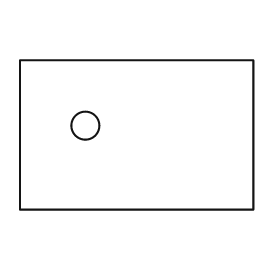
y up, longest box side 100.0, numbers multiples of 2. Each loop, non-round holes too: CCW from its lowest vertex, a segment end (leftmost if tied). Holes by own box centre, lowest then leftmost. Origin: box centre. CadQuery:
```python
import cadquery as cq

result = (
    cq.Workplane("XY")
    .moveTo(-50.0, -32.0)
    .lineTo(50.0, -32.0)
    .lineTo(50.0, 32.0)
    .lineTo(-50.0, 32.0)
    .close()
    .moveTo(-22.0, 4.0)
    .circle(6.0)
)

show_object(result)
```